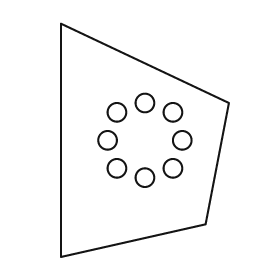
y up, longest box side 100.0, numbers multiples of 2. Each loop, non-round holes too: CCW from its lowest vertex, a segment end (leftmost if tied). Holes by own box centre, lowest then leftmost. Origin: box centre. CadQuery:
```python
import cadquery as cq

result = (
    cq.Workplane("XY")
    .moveTo(-36.0, -50.0)
    .lineTo(26.0, -36.0)
    .lineTo(36.0, 16.0)
    .lineTo(-36.0, 50.0)
    .close()
    .moveTo(0.0, -16.0)
    .circle(4.0)
    .moveTo(-12.0, -12.0)
    .circle(4.0)
    .moveTo(12.0, -12.0)
    .circle(4.0)
    .moveTo(-16.0, 0.0)
    .circle(4.0)
    .moveTo(16.0, 0.0)
    .circle(4.0)
    .moveTo(-12.0, 12.0)
    .circle(4.0)
    .moveTo(12.0, 12.0)
    .circle(4.0)
    .moveTo(0.0, 16.0)
    .circle(4.0)
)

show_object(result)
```